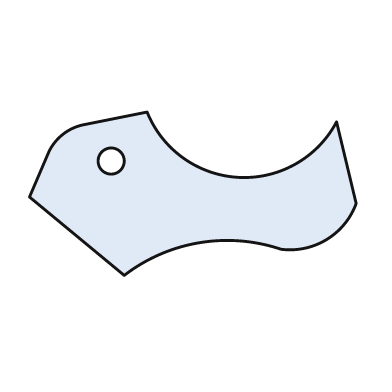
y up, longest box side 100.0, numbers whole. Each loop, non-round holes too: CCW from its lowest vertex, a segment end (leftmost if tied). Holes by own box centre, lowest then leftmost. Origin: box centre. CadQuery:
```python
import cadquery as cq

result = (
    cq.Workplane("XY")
    .moveTo(-21.0, -25.0)
    .threePointArc((2.0, -15.0), (27.0, -17.0))
    .threePointArc((41.0, -14.0), (50.0, -3.0))
    .lineTo(44.0, 22.0)
    .threePointArc((14.0, 5.0), (-14.0, 25.0))
    .lineTo(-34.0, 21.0)
    .threePointArc((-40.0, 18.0), (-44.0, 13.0))
    .lineTo(-50.0, -1.0)
    .close()
    .moveTo(-25.0, 10.0)
    .circle(4.0)
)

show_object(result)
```